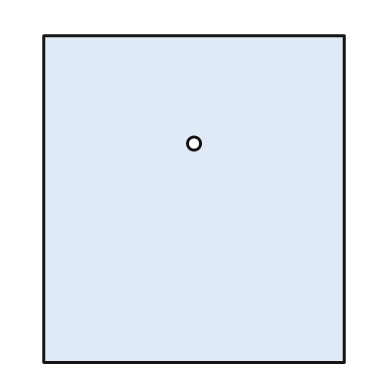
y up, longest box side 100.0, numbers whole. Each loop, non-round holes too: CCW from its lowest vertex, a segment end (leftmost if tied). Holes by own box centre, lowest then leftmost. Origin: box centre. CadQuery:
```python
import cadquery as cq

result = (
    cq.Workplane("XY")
    .moveTo(-46.0, -50.0)
    .lineTo(46.0, -50.0)
    .lineTo(46.0, 50.0)
    .lineTo(-46.0, 50.0)
    .close()
    .moveTo(0.0, 17.0)
    .circle(2.0)
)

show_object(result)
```